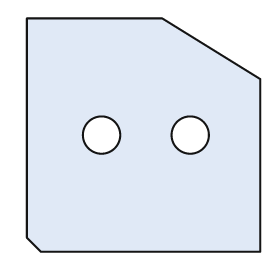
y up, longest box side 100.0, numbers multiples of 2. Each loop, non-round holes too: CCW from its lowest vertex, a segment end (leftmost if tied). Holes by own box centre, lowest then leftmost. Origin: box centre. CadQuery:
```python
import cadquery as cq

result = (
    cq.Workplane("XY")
    .moveTo(-44.0, -50.0)
    .lineTo(50.0, -50.0)
    .lineTo(50.0, 24.0)
    .lineTo(8.0, 50.0)
    .lineTo(-50.0, 50.0)
    .lineTo(-50.0, -44.0)
    .close()
    .moveTo(-18.0, 0.0)
    .circle(8.0)
    .moveTo(20.0, 0.0)
    .circle(8.0)
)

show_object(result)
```